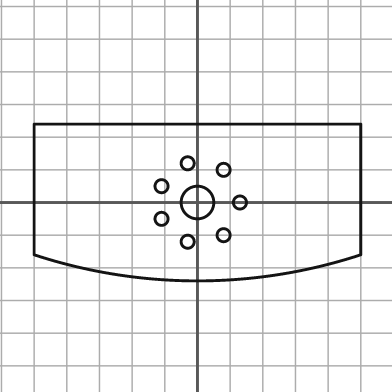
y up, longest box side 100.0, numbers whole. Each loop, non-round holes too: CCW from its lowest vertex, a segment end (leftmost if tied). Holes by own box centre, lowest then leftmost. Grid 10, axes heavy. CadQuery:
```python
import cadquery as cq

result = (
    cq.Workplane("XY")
    .moveTo(-50.0, -16.0)
    .threePointArc((0.0, -24.0), (50.0, -16.0))
    .lineTo(50.0, 24.0)
    .lineTo(-50.0, 24.0)
    .close()
    .moveTo(-3.0, -12.0)
    .circle(2.0)
    .moveTo(8.0, -10.0)
    .circle(2.0)
    .moveTo(-11.0, -5.0)
    .circle(2.0)
    .moveTo(0.0, 0.0)
    .circle(5.0)
    .moveTo(13.0, 0.0)
    .circle(2.0)
    .moveTo(-11.0, 5.0)
    .circle(2.0)
    .moveTo(8.0, 10.0)
    .circle(2.0)
    .moveTo(-3.0, 12.0)
    .circle(2.0)
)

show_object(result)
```